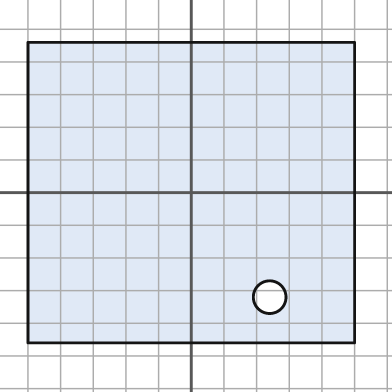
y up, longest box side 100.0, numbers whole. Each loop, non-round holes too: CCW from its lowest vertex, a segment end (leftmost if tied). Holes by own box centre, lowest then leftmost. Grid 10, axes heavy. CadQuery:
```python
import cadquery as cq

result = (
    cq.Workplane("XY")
    .moveTo(-50.0, -46.0)
    .lineTo(50.0, -46.0)
    .lineTo(50.0, 46.0)
    .lineTo(-50.0, 46.0)
    .close()
    .moveTo(24.0, -32.0)
    .circle(5.0)
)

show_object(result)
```